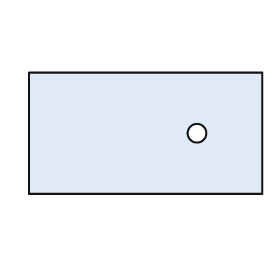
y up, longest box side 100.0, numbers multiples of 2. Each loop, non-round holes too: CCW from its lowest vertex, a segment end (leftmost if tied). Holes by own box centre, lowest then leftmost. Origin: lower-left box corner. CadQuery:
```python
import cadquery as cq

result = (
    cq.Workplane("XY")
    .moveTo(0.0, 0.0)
    .lineTo(100.0, 0.0)
    .lineTo(100.0, 52.0)
    .lineTo(0.0, 52.0)
    .close()
    .moveTo(72.0, 26.0)
    .circle(4.0)
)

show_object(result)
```